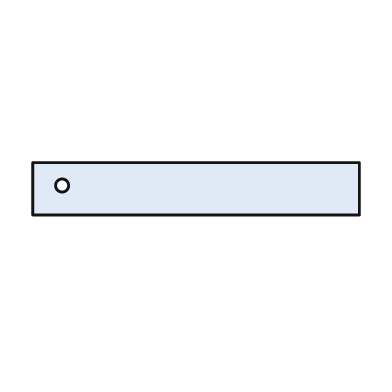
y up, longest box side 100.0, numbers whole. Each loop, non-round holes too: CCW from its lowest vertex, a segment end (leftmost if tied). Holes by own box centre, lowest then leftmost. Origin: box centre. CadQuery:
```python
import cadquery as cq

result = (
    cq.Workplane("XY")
    .moveTo(-50.0, -8.0)
    .lineTo(50.0, -8.0)
    .lineTo(50.0, 8.0)
    .lineTo(-50.0, 8.0)
    .close()
    .moveTo(-41.0, 1.0)
    .circle(2.0)
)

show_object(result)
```